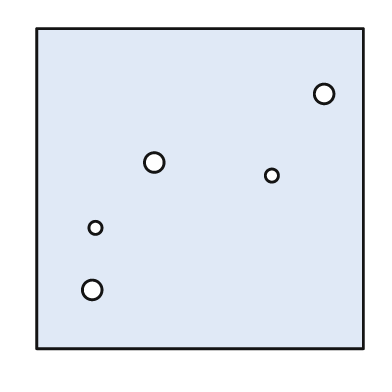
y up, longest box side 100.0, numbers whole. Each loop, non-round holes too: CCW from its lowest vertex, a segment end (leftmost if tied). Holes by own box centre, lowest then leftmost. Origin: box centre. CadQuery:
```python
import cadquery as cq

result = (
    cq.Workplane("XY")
    .moveTo(-50.0, -49.0)
    .lineTo(50.0, -49.0)
    .lineTo(50.0, 49.0)
    .lineTo(-50.0, 49.0)
    .close()
    .moveTo(-33.0, -31.0)
    .circle(3.0)
    .moveTo(-32.0, -12.0)
    .circle(2.0)
    .moveTo(22.0, 4.0)
    .circle(2.0)
    .moveTo(-14.0, 8.0)
    .circle(3.0)
    .moveTo(38.0, 29.0)
    .circle(3.0)
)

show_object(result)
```